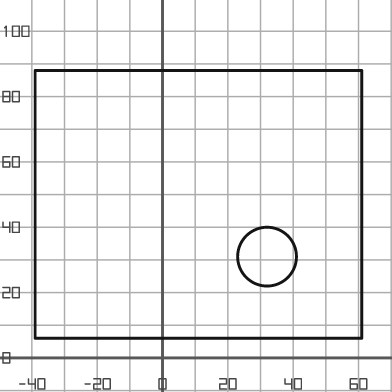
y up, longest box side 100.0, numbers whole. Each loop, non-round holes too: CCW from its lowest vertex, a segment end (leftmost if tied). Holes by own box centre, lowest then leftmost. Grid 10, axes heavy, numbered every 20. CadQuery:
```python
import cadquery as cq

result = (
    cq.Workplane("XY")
    .moveTo(-39.0, 6.0)
    .lineTo(61.0, 6.0)
    .lineTo(61.0, 88.0)
    .lineTo(-39.0, 88.0)
    .close()
    .moveTo(32.0, 31.0)
    .circle(9.0)
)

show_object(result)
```